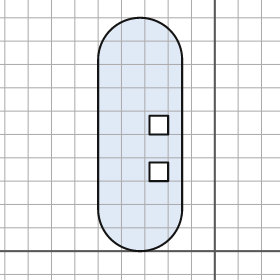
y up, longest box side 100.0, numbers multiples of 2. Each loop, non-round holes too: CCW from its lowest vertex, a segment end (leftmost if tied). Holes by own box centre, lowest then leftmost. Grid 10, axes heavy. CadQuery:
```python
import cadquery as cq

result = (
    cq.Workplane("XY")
    .moveTo(-50.0, 18.0)
    .threePointArc((-32.0, 0.0), (-14.0, 18.0))
    .lineTo(-14.0, 82.0)
    .threePointArc((-32.0, 100.0), (-50.0, 82.0))
    .close()
    .moveTo(-28.0, 30.0)
    .lineTo(-20.0, 30.0)
    .lineTo(-20.0, 38.0)
    .lineTo(-28.0, 38.0)
    .close()
    .moveTo(-28.0, 50.0)
    .lineTo(-20.0, 50.0)
    .lineTo(-20.0, 58.0)
    .lineTo(-28.0, 58.0)
    .close()
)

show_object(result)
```